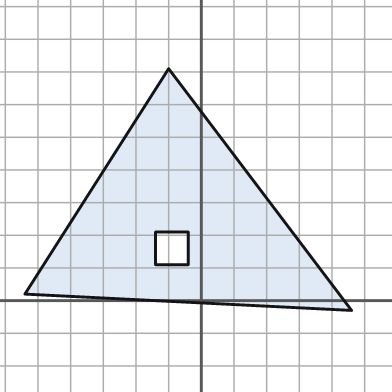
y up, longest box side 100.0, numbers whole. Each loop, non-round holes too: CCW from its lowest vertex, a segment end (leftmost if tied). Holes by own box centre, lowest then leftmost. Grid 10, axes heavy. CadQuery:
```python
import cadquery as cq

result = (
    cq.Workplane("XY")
    .moveTo(46.0, -3.0)
    .lineTo(-10.0, 71.0)
    .lineTo(-54.0, 2.0)
    .close()
    .moveTo(-14.0, 11.0)
    .lineTo(-4.0, 11.0)
    .lineTo(-4.0, 21.0)
    .lineTo(-14.0, 21.0)
    .close()
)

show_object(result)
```